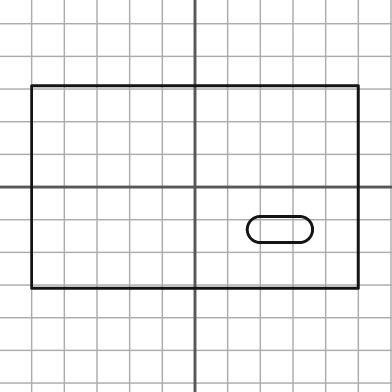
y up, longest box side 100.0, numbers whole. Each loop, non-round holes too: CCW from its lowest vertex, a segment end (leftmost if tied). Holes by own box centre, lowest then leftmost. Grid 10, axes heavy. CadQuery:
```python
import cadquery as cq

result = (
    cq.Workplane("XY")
    .moveTo(-50.0, -31.0)
    .lineTo(50.0, -31.0)
    .lineTo(50.0, 31.0)
    .lineTo(-50.0, 31.0)
    .close()
    .moveTo(20.0, -17.0)
    .lineTo(32.0, -17.0)
    .threePointArc((36.0, -13.0), (32.0, -9.0))
    .lineTo(20.0, -9.0)
    .threePointArc((16.0, -13.0), (20.0, -17.0))
    .close()
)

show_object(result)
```